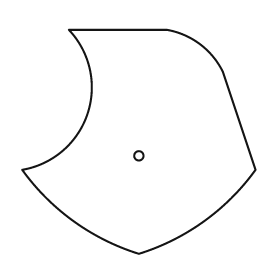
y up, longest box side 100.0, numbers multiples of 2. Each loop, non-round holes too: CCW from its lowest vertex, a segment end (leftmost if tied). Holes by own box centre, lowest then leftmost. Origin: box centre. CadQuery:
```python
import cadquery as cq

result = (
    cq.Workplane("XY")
    .moveTo(0.0, -48.0)
    .threePointArc((28.0, -34.0), (50.0, -12.0))
    .lineTo(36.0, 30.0)
    .threePointArc((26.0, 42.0), (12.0, 48.0))
    .lineTo(-30.0, 48.0)
    .threePointArc((-22.0, 12.0), (-50.0, -12.0))
    .threePointArc((-28.0, -34.0), (0.0, -48.0))
    .close()
    .moveTo(0.0, -6.0)
    .circle(2.0)
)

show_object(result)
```